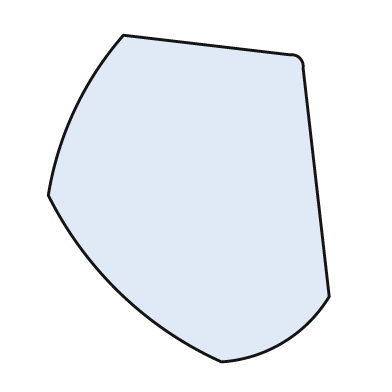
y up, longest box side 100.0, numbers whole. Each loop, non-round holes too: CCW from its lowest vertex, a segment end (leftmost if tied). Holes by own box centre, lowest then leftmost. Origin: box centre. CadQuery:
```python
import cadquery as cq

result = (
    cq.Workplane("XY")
    .moveTo(10.0, -50.0)
    .threePointArc((29.0, -44.0), (43.0, -30.0))
    .lineTo(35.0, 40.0)
    .threePointArc((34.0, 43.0), (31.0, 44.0))
    .lineTo(-20.0, 50.0)
    .threePointArc((-35.0, 27.0), (-43.0, 1.0))
    .threePointArc((-21.0, -29.0), (10.0, -50.0))
    .close()
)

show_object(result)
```